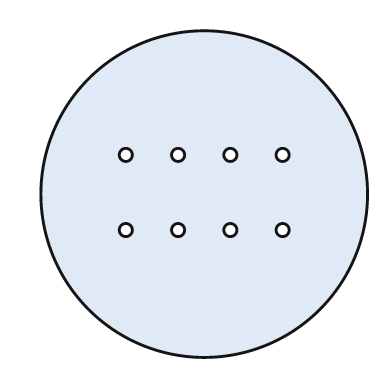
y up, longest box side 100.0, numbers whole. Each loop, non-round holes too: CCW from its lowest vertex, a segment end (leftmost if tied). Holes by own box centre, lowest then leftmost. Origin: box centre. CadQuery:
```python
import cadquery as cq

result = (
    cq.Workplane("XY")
    .moveTo(0.0, 0.0)
    .circle(50.0)
    .moveTo(-24.0, -11.0)
    .circle(2.0)
    .moveTo(-8.0, -11.0)
    .circle(2.0)
    .moveTo(8.0, -11.0)
    .circle(2.0)
    .moveTo(24.0, -11.0)
    .circle(2.0)
    .moveTo(-24.0, 12.0)
    .circle(2.0)
    .moveTo(-8.0, 12.0)
    .circle(2.0)
    .moveTo(8.0, 12.0)
    .circle(2.0)
    .moveTo(24.0, 12.0)
    .circle(2.0)
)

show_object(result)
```